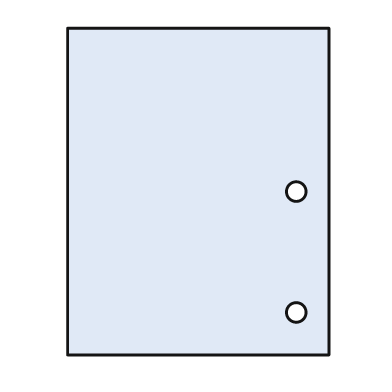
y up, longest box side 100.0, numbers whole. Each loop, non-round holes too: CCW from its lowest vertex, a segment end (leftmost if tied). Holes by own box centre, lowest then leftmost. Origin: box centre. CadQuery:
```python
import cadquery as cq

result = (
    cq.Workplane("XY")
    .moveTo(-40.0, -50.0)
    .lineTo(40.0, -50.0)
    .lineTo(40.0, 50.0)
    .lineTo(-40.0, 50.0)
    .close()
    .moveTo(30.0, -37.0)
    .circle(3.0)
    .moveTo(30.0, 0.0)
    .circle(3.0)
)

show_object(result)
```